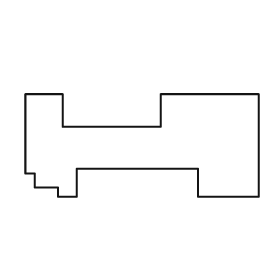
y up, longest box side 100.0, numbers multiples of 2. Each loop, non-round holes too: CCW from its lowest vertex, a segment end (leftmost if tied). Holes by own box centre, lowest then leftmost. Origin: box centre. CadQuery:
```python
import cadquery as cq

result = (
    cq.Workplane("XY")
    .moveTo(-36.0, -22.0)
    .lineTo(-28.0, -22.0)
    .lineTo(-28.0, -10.0)
    .lineTo(24.0, -10.0)
    .lineTo(24.0, -22.0)
    .lineTo(50.0, -22.0)
    .lineTo(50.0, 22.0)
    .lineTo(8.0, 22.0)
    .lineTo(8.0, 8.0)
    .lineTo(-34.0, 8.0)
    .lineTo(-34.0, 22.0)
    .lineTo(-50.0, 22.0)
    .lineTo(-50.0, -12.0)
    .lineTo(-46.0, -12.0)
    .lineTo(-46.0, -18.0)
    .lineTo(-36.0, -18.0)
    .close()
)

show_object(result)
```